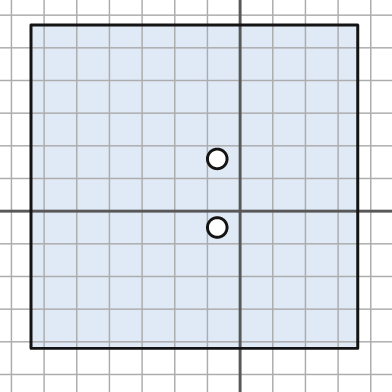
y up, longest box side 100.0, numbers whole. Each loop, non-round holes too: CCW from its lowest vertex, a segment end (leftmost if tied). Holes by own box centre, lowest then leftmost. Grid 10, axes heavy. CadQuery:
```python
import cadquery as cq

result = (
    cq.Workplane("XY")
    .moveTo(-64.0, -42.0)
    .lineTo(36.0, -42.0)
    .lineTo(36.0, 57.0)
    .lineTo(-64.0, 57.0)
    .close()
    .moveTo(-7.0, -5.0)
    .circle(3.0)
    .moveTo(-7.0, 16.0)
    .circle(3.0)
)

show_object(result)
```